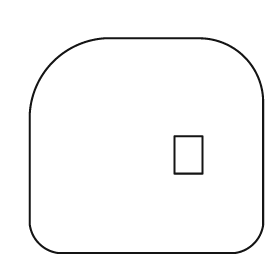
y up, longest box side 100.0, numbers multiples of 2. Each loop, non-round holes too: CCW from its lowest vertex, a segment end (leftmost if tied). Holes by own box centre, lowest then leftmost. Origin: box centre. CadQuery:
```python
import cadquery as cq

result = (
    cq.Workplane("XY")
    .moveTo(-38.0, -46.0)
    .lineTo(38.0, -46.0)
    .threePointArc((46.0, -42.0), (50.0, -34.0))
    .lineTo(50.0, 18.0)
    .threePointArc((42.0, 38.0), (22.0, 46.0))
    .lineTo(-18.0, 46.0)
    .threePointArc((-40.0, 36.0), (-50.0, 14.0))
    .lineTo(-50.0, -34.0)
    .threePointArc((-46.0, -42.0), (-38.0, -46.0))
    .close()
    .moveTo(12.0, -12.0)
    .lineTo(24.0, -12.0)
    .lineTo(24.0, 4.0)
    .lineTo(12.0, 4.0)
    .close()
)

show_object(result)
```